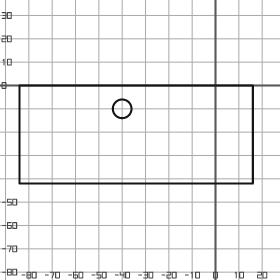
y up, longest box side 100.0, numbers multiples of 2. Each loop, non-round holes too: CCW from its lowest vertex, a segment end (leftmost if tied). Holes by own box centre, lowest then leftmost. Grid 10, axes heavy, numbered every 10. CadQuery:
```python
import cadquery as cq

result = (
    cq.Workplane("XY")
    .moveTo(-84.0, -42.0)
    .lineTo(16.0, -42.0)
    .lineTo(16.0, 0.0)
    .lineTo(-84.0, 0.0)
    .close()
    .moveTo(-40.0, -10.0)
    .circle(4.0)
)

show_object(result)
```